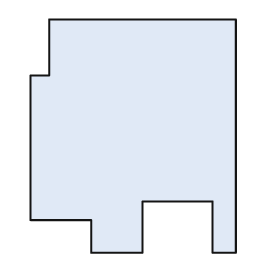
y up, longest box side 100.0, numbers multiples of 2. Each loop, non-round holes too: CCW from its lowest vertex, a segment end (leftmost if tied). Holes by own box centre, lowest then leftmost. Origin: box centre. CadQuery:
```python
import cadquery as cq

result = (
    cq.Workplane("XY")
    .moveTo(-18.0, -50.0)
    .lineTo(4.0, -50.0)
    .lineTo(4.0, -28.0)
    .lineTo(34.0, -28.0)
    .lineTo(34.0, -50.0)
    .lineTo(44.0, -50.0)
    .lineTo(44.0, 50.0)
    .lineTo(-36.0, 50.0)
    .lineTo(-36.0, 26.0)
    .lineTo(-44.0, 26.0)
    .lineTo(-44.0, -36.0)
    .lineTo(-18.0, -36.0)
    .close()
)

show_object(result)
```